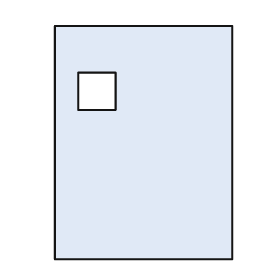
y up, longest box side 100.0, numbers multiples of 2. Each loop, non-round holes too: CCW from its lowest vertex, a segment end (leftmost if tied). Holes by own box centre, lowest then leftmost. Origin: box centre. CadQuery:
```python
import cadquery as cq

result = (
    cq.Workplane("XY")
    .moveTo(-38.0, -50.0)
    .lineTo(38.0, -50.0)
    .lineTo(38.0, 50.0)
    .lineTo(-38.0, 50.0)
    .close()
    .moveTo(-28.0, 14.0)
    .lineTo(-12.0, 14.0)
    .lineTo(-12.0, 30.0)
    .lineTo(-28.0, 30.0)
    .close()
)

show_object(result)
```